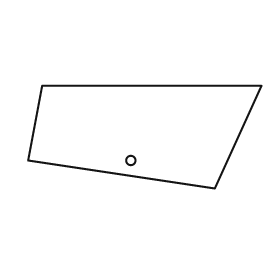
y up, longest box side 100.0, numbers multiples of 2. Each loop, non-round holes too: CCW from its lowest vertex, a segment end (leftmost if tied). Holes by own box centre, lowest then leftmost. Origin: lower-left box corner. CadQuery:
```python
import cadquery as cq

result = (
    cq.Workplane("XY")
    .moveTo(80.0, 0.0)
    .lineTo(100.0, 44.0)
    .lineTo(6.0, 44.0)
    .lineTo(0.0, 12.0)
    .close()
    .moveTo(44.0, 12.0)
    .circle(2.0)
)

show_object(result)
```